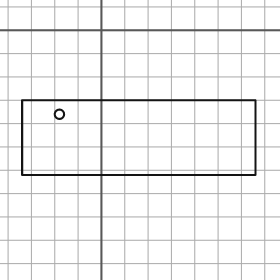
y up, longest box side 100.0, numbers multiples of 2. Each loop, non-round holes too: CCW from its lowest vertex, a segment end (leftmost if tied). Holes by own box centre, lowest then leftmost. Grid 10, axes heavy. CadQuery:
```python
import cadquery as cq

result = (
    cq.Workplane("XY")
    .moveTo(-34.0, -62.0)
    .lineTo(66.0, -62.0)
    .lineTo(66.0, -30.0)
    .lineTo(-34.0, -30.0)
    .close()
    .moveTo(-18.0, -36.0)
    .circle(2.0)
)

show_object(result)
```